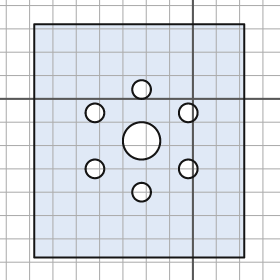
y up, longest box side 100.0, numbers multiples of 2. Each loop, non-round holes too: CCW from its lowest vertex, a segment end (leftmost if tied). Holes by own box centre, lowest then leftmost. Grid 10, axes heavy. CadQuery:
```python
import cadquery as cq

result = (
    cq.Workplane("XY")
    .moveTo(-68.0, -68.0)
    .lineTo(22.0, -68.0)
    .lineTo(22.0, 32.0)
    .lineTo(-68.0, 32.0)
    .close()
    .moveTo(-22.0, -40.0)
    .circle(4.0)
    .moveTo(-42.0, -30.0)
    .circle(4.0)
    .moveTo(-2.0, -30.0)
    .circle(4.0)
    .moveTo(-22.0, -18.0)
    .circle(8.0)
    .moveTo(-42.0, -6.0)
    .circle(4.0)
    .moveTo(-2.0, -6.0)
    .circle(4.0)
    .moveTo(-22.0, 4.0)
    .circle(4.0)
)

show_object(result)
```